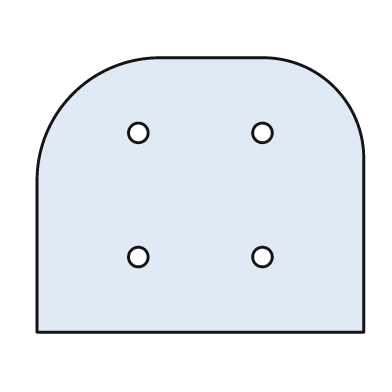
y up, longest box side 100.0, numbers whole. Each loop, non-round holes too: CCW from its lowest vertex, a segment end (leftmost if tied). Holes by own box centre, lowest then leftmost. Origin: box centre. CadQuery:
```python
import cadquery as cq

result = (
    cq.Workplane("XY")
    .moveTo(-50.0, -42.0)
    .lineTo(50.0, -42.0)
    .lineTo(50.0, 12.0)
    .threePointArc((41.0, 33.0), (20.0, 42.0))
    .lineTo(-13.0, 42.0)
    .threePointArc((-39.0, 31.0), (-50.0, 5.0))
    .close()
    .moveTo(-19.0, -19.0)
    .circle(3.0)
    .moveTo(19.0, -19.0)
    .circle(3.0)
    .moveTo(-19.0, 19.0)
    .circle(3.0)
    .moveTo(19.0, 19.0)
    .circle(3.0)
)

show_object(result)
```